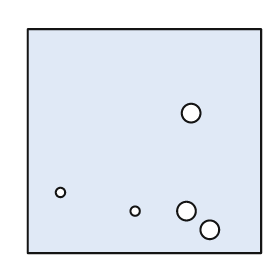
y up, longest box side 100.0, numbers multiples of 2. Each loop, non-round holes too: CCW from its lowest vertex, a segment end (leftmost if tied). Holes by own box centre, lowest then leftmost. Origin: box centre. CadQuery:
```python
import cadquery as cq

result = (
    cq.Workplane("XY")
    .moveTo(-50.0, -48.0)
    .lineTo(50.0, -48.0)
    .lineTo(50.0, 48.0)
    .lineTo(-50.0, 48.0)
    .close()
    .moveTo(28.0, -38.0)
    .circle(4.0)
    .moveTo(-4.0, -30.0)
    .circle(2.0)
    .moveTo(18.0, -30.0)
    .circle(4.0)
    .moveTo(-36.0, -22.0)
    .circle(2.0)
    .moveTo(20.0, 12.0)
    .circle(4.0)
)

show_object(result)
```